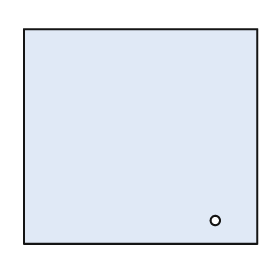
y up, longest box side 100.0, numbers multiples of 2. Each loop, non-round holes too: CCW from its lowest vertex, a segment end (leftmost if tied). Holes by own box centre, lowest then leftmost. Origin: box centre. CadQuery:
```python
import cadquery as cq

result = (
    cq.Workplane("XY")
    .moveTo(-50.0, -46.0)
    .lineTo(50.0, -46.0)
    .lineTo(50.0, 46.0)
    .lineTo(-50.0, 46.0)
    .close()
    .moveTo(32.0, -36.0)
    .circle(2.0)
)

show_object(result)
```